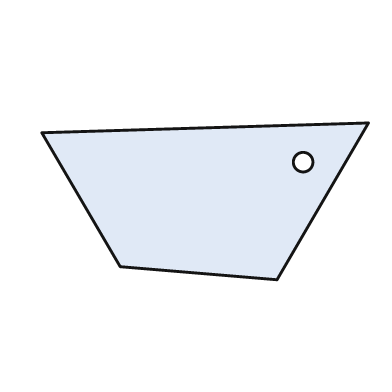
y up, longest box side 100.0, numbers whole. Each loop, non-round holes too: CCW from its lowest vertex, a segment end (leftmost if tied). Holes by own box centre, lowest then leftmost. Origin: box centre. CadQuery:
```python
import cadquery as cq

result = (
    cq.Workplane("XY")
    .moveTo(22.0, -24.0)
    .lineTo(50.0, 24.0)
    .lineTo(-50.0, 21.0)
    .lineTo(-26.0, -20.0)
    .close()
    .moveTo(30.0, 12.0)
    .circle(3.0)
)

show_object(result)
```